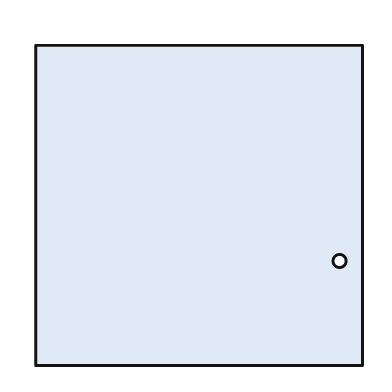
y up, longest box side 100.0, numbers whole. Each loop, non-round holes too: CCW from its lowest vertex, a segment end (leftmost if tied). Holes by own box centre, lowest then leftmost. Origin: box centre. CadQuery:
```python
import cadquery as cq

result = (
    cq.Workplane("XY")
    .moveTo(-50.0, -49.0)
    .lineTo(50.0, -49.0)
    .lineTo(50.0, 49.0)
    .lineTo(-50.0, 49.0)
    .close()
    .moveTo(43.0, -17.0)
    .circle(2.0)
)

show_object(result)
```